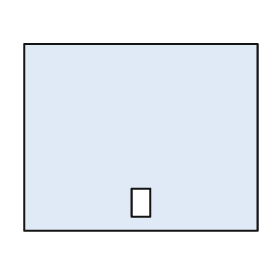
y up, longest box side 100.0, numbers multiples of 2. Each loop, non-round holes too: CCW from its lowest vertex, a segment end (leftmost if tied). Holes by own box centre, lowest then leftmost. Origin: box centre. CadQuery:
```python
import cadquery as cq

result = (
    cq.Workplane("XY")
    .moveTo(-50.0, -40.0)
    .lineTo(50.0, -40.0)
    .lineTo(50.0, 40.0)
    .lineTo(-50.0, 40.0)
    .close()
    .moveTo(-4.0, -34.0)
    .lineTo(4.0, -34.0)
    .lineTo(4.0, -22.0)
    .lineTo(-4.0, -22.0)
    .close()
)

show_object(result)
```